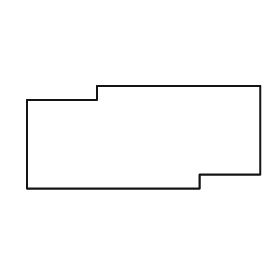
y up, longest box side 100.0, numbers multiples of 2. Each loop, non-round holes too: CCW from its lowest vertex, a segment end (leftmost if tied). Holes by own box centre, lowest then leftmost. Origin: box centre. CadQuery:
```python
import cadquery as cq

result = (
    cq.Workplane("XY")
    .moveTo(-50.0, -22.0)
    .lineTo(24.0, -22.0)
    .lineTo(24.0, -16.0)
    .lineTo(50.0, -16.0)
    .lineTo(50.0, 22.0)
    .lineTo(-20.0, 22.0)
    .lineTo(-20.0, 16.0)
    .lineTo(-50.0, 16.0)
    .close()
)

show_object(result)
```